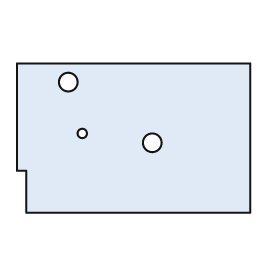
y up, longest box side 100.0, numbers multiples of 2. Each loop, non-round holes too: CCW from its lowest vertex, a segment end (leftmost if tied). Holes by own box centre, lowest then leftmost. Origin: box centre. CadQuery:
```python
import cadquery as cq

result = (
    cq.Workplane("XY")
    .moveTo(-46.0, -32.0)
    .lineTo(50.0, -32.0)
    .lineTo(50.0, 32.0)
    .lineTo(-50.0, 32.0)
    .lineTo(-50.0, -14.0)
    .lineTo(-46.0, -14.0)
    .close()
    .moveTo(8.0, -2.0)
    .circle(4.0)
    .moveTo(-22.0, 2.0)
    .circle(2.0)
    .moveTo(-28.0, 24.0)
    .circle(4.0)
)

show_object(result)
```